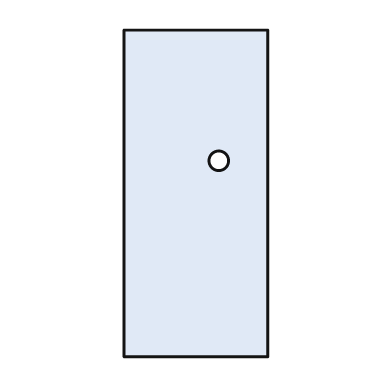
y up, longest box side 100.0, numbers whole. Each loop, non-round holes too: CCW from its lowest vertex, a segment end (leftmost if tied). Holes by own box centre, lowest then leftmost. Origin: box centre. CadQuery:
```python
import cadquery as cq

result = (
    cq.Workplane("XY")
    .moveTo(-22.0, -50.0)
    .lineTo(22.0, -50.0)
    .lineTo(22.0, 50.0)
    .lineTo(-22.0, 50.0)
    .close()
    .moveTo(7.0, 10.0)
    .circle(3.0)
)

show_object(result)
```